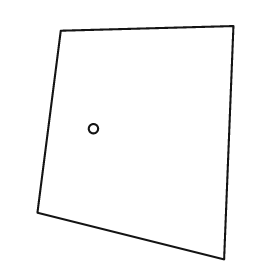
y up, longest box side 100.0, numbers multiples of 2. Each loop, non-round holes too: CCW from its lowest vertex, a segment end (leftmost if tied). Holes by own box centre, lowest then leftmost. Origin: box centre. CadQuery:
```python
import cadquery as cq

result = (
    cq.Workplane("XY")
    .moveTo(38.0, -50.0)
    .lineTo(42.0, 50.0)
    .lineTo(-32.0, 48.0)
    .lineTo(-42.0, -30.0)
    .close()
    .moveTo(-18.0, 6.0)
    .circle(2.0)
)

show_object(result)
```